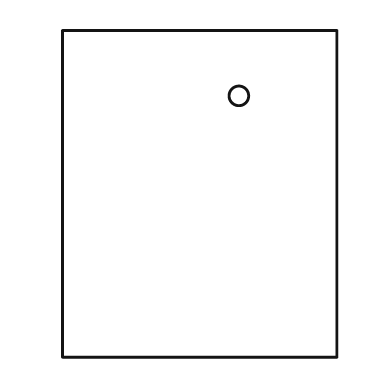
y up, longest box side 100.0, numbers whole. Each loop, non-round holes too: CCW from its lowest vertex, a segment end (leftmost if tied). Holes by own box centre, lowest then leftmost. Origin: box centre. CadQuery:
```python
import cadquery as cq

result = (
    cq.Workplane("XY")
    .moveTo(-42.0, -50.0)
    .lineTo(42.0, -50.0)
    .lineTo(42.0, 50.0)
    .lineTo(-42.0, 50.0)
    .close()
    .moveTo(12.0, 30.0)
    .circle(3.0)
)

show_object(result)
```